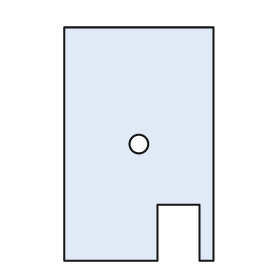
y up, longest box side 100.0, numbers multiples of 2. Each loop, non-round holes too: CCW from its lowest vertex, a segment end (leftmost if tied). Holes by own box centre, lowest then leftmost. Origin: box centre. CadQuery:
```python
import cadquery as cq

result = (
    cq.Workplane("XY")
    .moveTo(-32.0, -50.0)
    .lineTo(8.0, -50.0)
    .lineTo(8.0, -26.0)
    .lineTo(26.0, -26.0)
    .lineTo(26.0, -50.0)
    .lineTo(32.0, -50.0)
    .lineTo(32.0, 50.0)
    .lineTo(-32.0, 50.0)
    .close()
    .moveTo(0.0, 0.0)
    .circle(4.0)
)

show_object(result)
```